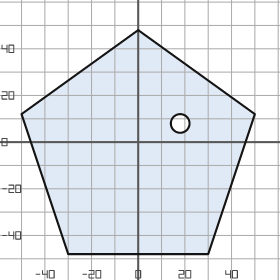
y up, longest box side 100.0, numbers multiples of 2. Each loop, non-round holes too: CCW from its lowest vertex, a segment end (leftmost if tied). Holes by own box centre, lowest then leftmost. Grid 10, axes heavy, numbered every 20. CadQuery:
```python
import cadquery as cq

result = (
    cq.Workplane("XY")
    .moveTo(-30.0, -48.0)
    .lineTo(30.0, -48.0)
    .lineTo(50.0, 12.0)
    .lineTo(0.0, 48.0)
    .lineTo(-50.0, 12.0)
    .close()
    .moveTo(18.0, 8.0)
    .circle(4.0)
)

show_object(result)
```